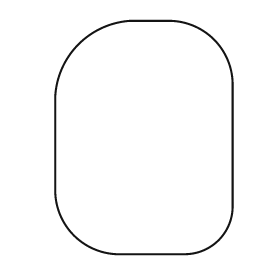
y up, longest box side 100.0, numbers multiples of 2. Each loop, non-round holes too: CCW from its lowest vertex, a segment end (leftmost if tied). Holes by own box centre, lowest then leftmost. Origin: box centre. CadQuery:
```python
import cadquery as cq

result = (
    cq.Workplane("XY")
    .moveTo(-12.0, -50.0)
    .lineTo(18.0, -50.0)
    .threePointArc((32.0, -44.0), (38.0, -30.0))
    .lineTo(38.0, 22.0)
    .threePointArc((30.0, 42.0), (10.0, 50.0))
    .lineTo(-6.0, 50.0)
    .threePointArc((-28.0, 40.0), (-38.0, 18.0))
    .lineTo(-38.0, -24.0)
    .threePointArc((-30.0, -42.0), (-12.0, -50.0))
    .close()
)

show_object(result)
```